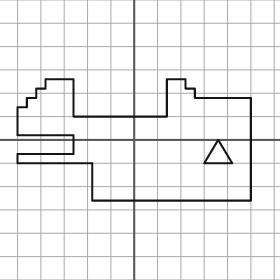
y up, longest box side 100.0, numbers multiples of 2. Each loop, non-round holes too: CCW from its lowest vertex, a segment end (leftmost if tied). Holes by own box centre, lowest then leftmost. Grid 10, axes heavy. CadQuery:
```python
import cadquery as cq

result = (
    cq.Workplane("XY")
    .moveTo(-18.0, -26.0)
    .lineTo(50.0, -26.0)
    .lineTo(50.0, 18.0)
    .lineTo(26.0, 18.0)
    .lineTo(26.0, 22.0)
    .lineTo(22.0, 22.0)
    .lineTo(22.0, 26.0)
    .lineTo(14.0, 26.0)
    .lineTo(14.0, 10.0)
    .lineTo(-26.0, 10.0)
    .lineTo(-26.0, 26.0)
    .lineTo(-38.0, 26.0)
    .lineTo(-38.0, 22.0)
    .lineTo(-42.0, 22.0)
    .lineTo(-42.0, 18.0)
    .lineTo(-46.0, 18.0)
    .lineTo(-46.0, 14.0)
    .lineTo(-50.0, 14.0)
    .lineTo(-50.0, 2.0)
    .lineTo(-26.0, 2.0)
    .lineTo(-26.0, -6.0)
    .lineTo(-50.0, -6.0)
    .lineTo(-50.0, -10.0)
    .lineTo(-18.0, -10.0)
    .close()
    .moveTo(30.0, -10.0)
    .lineTo(42.0, -10.0)
    .lineTo(36.0, 0.0)
    .close()
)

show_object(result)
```